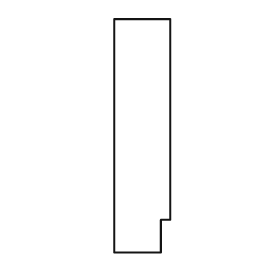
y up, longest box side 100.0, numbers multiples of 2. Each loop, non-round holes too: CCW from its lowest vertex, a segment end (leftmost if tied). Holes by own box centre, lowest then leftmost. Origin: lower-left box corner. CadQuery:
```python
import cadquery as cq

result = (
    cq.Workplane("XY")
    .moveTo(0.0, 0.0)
    .lineTo(20.0, 0.0)
    .lineTo(20.0, 14.0)
    .lineTo(24.0, 14.0)
    .lineTo(24.0, 100.0)
    .lineTo(0.0, 100.0)
    .close()
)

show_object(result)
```